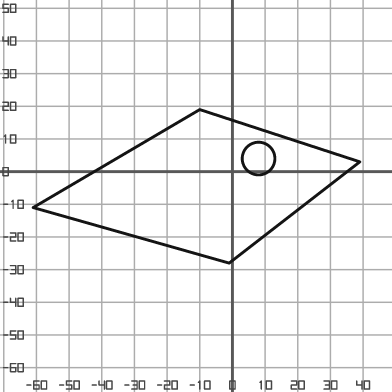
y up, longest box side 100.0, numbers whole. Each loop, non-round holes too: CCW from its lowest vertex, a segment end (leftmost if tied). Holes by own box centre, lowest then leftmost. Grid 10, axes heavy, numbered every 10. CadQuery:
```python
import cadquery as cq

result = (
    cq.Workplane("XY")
    .moveTo(-1.0, -28.0)
    .lineTo(39.0, 3.0)
    .lineTo(-10.0, 19.0)
    .lineTo(-61.0, -11.0)
    .close()
    .moveTo(8.0, 4.0)
    .circle(5.0)
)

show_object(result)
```